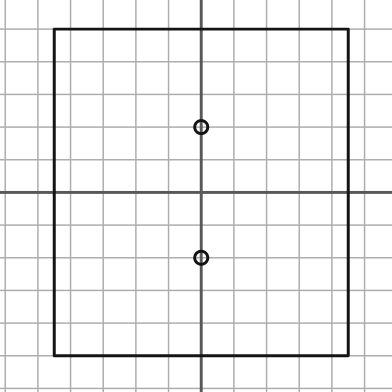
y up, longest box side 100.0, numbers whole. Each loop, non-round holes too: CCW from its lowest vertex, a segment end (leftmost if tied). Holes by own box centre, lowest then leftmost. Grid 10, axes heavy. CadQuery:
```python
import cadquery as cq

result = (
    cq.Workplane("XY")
    .moveTo(-45.0, -50.0)
    .lineTo(45.0, -50.0)
    .lineTo(45.0, 50.0)
    .lineTo(-45.0, 50.0)
    .close()
    .moveTo(0.0, -20.0)
    .circle(2.0)
    .moveTo(0.0, 20.0)
    .circle(2.0)
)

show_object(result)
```